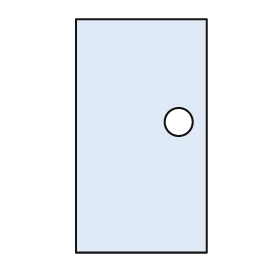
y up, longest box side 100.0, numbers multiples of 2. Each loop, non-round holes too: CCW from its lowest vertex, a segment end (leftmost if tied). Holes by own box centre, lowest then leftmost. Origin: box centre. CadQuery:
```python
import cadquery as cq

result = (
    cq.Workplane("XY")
    .moveTo(-28.0, -50.0)
    .lineTo(28.0, -50.0)
    .lineTo(28.0, 50.0)
    .lineTo(-28.0, 50.0)
    .close()
    .moveTo(16.0, 6.0)
    .circle(6.0)
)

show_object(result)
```